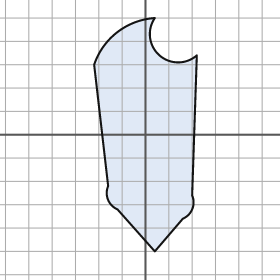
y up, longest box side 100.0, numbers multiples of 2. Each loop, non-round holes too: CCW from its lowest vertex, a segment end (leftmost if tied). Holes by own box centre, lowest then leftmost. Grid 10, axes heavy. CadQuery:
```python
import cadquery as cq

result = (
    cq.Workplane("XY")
    .moveTo(4.0, -50.0)
    .lineTo(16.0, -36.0)
    .threePointArc((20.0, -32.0), (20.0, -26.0))
    .lineTo(22.0, 34.0)
    .threePointArc((6.0, 34.0), (4.0, 50.0))
    .threePointArc((-12.0, 44.0), (-22.0, 30.0))
    .lineTo(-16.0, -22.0)
    .threePointArc((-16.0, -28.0), (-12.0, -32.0))
    .close()
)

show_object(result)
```